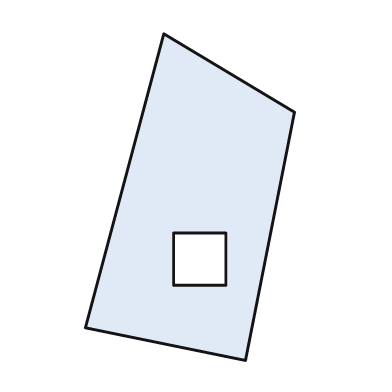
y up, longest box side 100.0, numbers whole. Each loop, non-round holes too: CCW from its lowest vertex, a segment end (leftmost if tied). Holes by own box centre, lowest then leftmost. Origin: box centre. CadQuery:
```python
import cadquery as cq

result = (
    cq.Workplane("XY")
    .moveTo(17.0, -50.0)
    .lineTo(32.0, 26.0)
    .lineTo(-8.0, 50.0)
    .lineTo(-32.0, -40.0)
    .close()
    .moveTo(-5.0, -27.0)
    .lineTo(11.0, -27.0)
    .lineTo(11.0, -11.0)
    .lineTo(-5.0, -11.0)
    .close()
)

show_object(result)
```